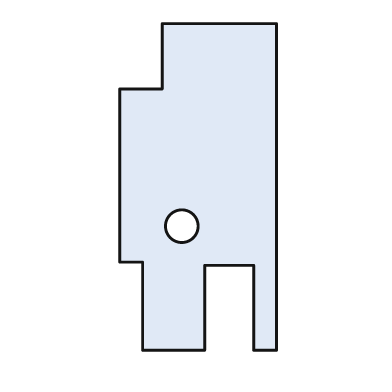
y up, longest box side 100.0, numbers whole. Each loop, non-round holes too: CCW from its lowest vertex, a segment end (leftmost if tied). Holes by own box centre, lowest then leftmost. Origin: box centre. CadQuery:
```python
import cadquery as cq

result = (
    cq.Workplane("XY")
    .moveTo(-17.0, -50.0)
    .lineTo(2.0, -50.0)
    .lineTo(2.0, -24.0)
    .lineTo(17.0, -24.0)
    .lineTo(17.0, -50.0)
    .lineTo(24.0, -50.0)
    .lineTo(24.0, 50.0)
    .lineTo(-11.0, 50.0)
    .lineTo(-11.0, 30.0)
    .lineTo(-24.0, 30.0)
    .lineTo(-24.0, -23.0)
    .lineTo(-17.0, -23.0)
    .close()
    .moveTo(-5.0, -12.0)
    .circle(5.0)
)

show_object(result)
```